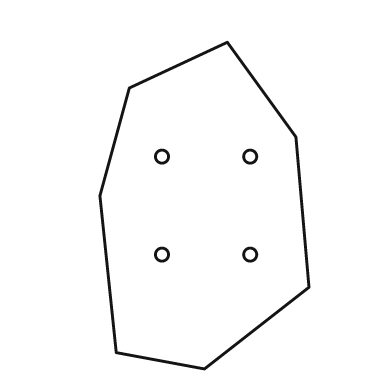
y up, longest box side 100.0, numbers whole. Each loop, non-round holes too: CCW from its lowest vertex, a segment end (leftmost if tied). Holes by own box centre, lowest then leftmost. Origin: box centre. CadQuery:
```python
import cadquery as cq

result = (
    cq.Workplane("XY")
    .moveTo(0.0, -50.0)
    .lineTo(32.0, -25.0)
    .lineTo(28.0, 21.0)
    .lineTo(7.0, 50.0)
    .lineTo(-23.0, 36.0)
    .lineTo(-32.0, 3.0)
    .lineTo(-27.0, -45.0)
    .close()
    .moveTo(-13.0, -15.0)
    .circle(2.0)
    .moveTo(14.0, -15.0)
    .circle(2.0)
    .moveTo(-13.0, 15.0)
    .circle(2.0)
    .moveTo(14.0, 15.0)
    .circle(2.0)
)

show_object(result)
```